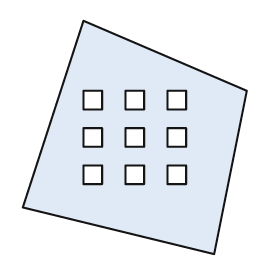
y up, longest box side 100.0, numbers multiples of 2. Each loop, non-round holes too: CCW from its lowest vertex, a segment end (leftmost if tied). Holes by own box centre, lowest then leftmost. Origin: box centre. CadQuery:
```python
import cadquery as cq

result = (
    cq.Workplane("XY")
    .moveTo(34.0, -50.0)
    .lineTo(48.0, 20.0)
    .lineTo(-22.0, 50.0)
    .lineTo(-48.0, -30.0)
    .close()
    .moveTo(-22.0, -20.0)
    .lineTo(-14.0, -20.0)
    .lineTo(-14.0, -12.0)
    .lineTo(-22.0, -12.0)
    .close()
    .moveTo(-4.0, -20.0)
    .lineTo(4.0, -20.0)
    .lineTo(4.0, -12.0)
    .lineTo(-4.0, -12.0)
    .close()
    .moveTo(14.0, -20.0)
    .lineTo(22.0, -20.0)
    .lineTo(22.0, -12.0)
    .lineTo(14.0, -12.0)
    .close()
    .moveTo(-22.0, -4.0)
    .lineTo(-14.0, -4.0)
    .lineTo(-14.0, 4.0)
    .lineTo(-22.0, 4.0)
    .close()
    .moveTo(-4.0, -4.0)
    .lineTo(4.0, -4.0)
    .lineTo(4.0, 4.0)
    .lineTo(-4.0, 4.0)
    .close()
    .moveTo(14.0, -4.0)
    .lineTo(22.0, -4.0)
    .lineTo(22.0, 4.0)
    .lineTo(14.0, 4.0)
    .close()
    .moveTo(-22.0, 12.0)
    .lineTo(-14.0, 12.0)
    .lineTo(-14.0, 20.0)
    .lineTo(-22.0, 20.0)
    .close()
    .moveTo(-4.0, 12.0)
    .lineTo(4.0, 12.0)
    .lineTo(4.0, 20.0)
    .lineTo(-4.0, 20.0)
    .close()
    .moveTo(14.0, 12.0)
    .lineTo(22.0, 12.0)
    .lineTo(22.0, 20.0)
    .lineTo(14.0, 20.0)
    .close()
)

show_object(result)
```